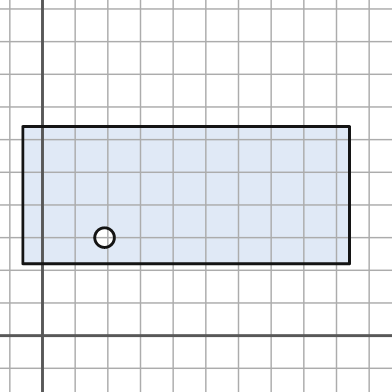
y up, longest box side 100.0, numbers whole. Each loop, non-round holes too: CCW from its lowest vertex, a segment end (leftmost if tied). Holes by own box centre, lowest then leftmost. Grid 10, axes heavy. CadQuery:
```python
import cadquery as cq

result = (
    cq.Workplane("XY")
    .moveTo(-6.0, 22.0)
    .lineTo(94.0, 22.0)
    .lineTo(94.0, 64.0)
    .lineTo(-6.0, 64.0)
    .close()
    .moveTo(19.0, 30.0)
    .circle(3.0)
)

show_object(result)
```